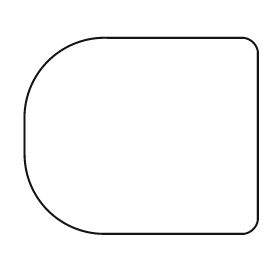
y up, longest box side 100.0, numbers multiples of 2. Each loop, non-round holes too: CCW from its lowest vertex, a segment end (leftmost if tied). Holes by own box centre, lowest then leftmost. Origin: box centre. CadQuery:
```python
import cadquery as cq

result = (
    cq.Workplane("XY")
    .moveTo(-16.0, -42.0)
    .lineTo(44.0, -42.0)
    .threePointArc((48.0, -40.0), (50.0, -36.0))
    .lineTo(50.0, 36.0)
    .threePointArc((48.0, 40.0), (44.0, 42.0))
    .lineTo(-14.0, 42.0)
    .threePointArc((-40.0, 32.0), (-50.0, 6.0))
    .lineTo(-50.0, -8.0)
    .threePointArc((-40.0, -32.0), (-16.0, -42.0))
    .close()
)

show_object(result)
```